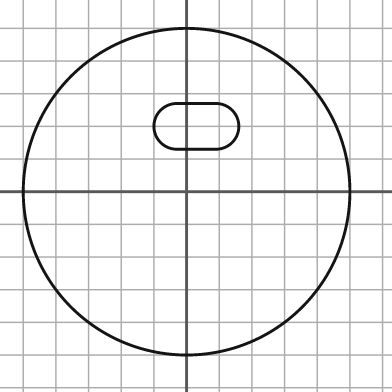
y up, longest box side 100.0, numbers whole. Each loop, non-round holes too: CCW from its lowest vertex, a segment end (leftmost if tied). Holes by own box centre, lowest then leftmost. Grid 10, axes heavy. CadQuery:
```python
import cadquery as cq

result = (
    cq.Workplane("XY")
    .moveTo(0.0, 0.0)
    .circle(50.0)
    .moveTo(-3.0, 13.0)
    .lineTo(9.0, 13.0)
    .threePointArc((16.0, 20.0), (9.0, 27.0))
    .lineTo(-3.0, 27.0)
    .threePointArc((-10.0, 20.0), (-3.0, 13.0))
    .close()
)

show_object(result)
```